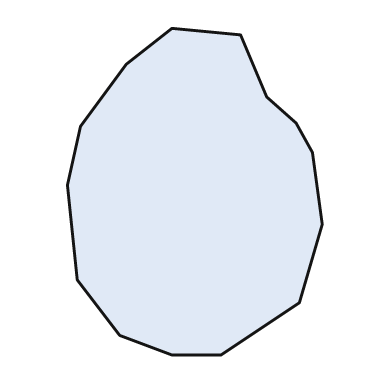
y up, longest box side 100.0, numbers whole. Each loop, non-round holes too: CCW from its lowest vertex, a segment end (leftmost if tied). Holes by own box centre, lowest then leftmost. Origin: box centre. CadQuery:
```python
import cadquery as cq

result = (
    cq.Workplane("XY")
    .moveTo(-7.0, -50.0)
    .lineTo(8.0, -50.0)
    .lineTo(32.0, -34.0)
    .lineTo(39.0, -10.0)
    .lineTo(36.0, 12.0)
    .lineTo(31.0, 21.0)
    .lineTo(22.0, 29.0)
    .lineTo(14.0, 48.0)
    .lineTo(-7.0, 50.0)
    .lineTo(-21.0, 39.0)
    .lineTo(-35.0, 20.0)
    .lineTo(-39.0, 2.0)
    .lineTo(-36.0, -27.0)
    .lineTo(-23.0, -44.0)
    .close()
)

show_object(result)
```